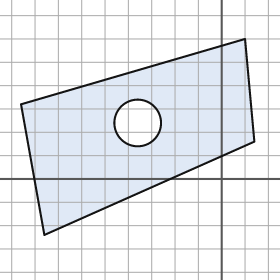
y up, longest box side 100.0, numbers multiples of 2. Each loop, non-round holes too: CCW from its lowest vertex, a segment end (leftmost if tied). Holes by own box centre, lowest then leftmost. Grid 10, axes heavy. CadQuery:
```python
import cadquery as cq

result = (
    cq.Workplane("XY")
    .moveTo(-76.0, -24.0)
    .lineTo(14.0, 16.0)
    .lineTo(10.0, 60.0)
    .lineTo(-86.0, 32.0)
    .close()
    .moveTo(-36.0, 24.0)
    .circle(10.0)
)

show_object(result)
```